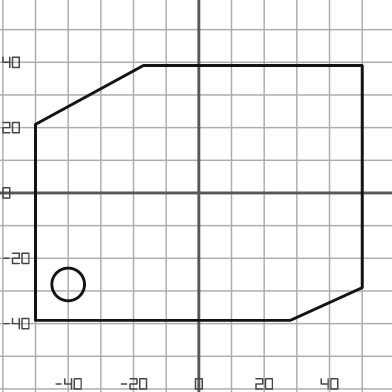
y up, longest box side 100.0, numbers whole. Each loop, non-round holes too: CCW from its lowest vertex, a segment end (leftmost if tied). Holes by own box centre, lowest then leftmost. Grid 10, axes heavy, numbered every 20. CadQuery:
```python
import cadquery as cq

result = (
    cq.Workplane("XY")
    .moveTo(-50.0, -39.0)
    .lineTo(28.0, -39.0)
    .lineTo(50.0, -29.0)
    .lineTo(50.0, 39.0)
    .lineTo(-17.0, 39.0)
    .lineTo(-50.0, 21.0)
    .close()
    .moveTo(-40.0, -28.0)
    .circle(5.0)
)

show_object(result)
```